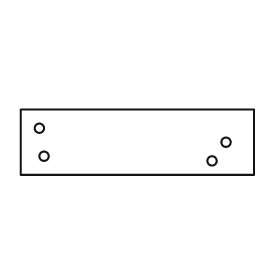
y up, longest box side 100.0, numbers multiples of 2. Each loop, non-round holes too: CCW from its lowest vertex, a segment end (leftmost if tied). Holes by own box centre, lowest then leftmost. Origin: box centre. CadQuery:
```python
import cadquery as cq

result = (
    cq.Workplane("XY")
    .moveTo(-50.0, -14.0)
    .lineTo(50.0, -14.0)
    .lineTo(50.0, 14.0)
    .lineTo(-50.0, 14.0)
    .close()
    .moveTo(32.0, -8.0)
    .circle(2.0)
    .moveTo(-40.0, -6.0)
    .circle(2.0)
    .moveTo(38.0, 0.0)
    .circle(2.0)
    .moveTo(-42.0, 6.0)
    .circle(2.0)
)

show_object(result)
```